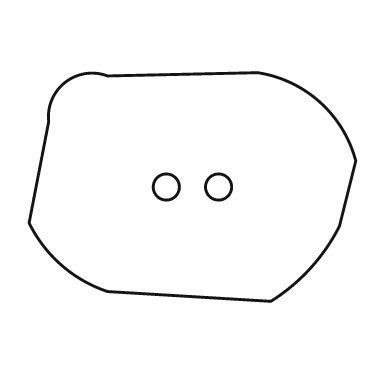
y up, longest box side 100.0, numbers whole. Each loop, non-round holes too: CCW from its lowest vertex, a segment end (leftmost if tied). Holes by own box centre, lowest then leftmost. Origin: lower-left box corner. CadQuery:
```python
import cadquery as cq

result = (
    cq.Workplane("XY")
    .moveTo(74.0, 0.0)
    .threePointArc((86.0, 10.0), (95.0, 23.0))
    .lineTo(100.0, 43.0)
    .threePointArc((89.0, 61.0), (70.0, 70.0))
    .lineTo(24.0, 69.0)
    .threePointArc((11.0, 67.0), (6.0, 55.0))
    .lineTo(0.0, 24.0)
    .threePointArc((10.0, 11.0), (24.0, 3.0))
    .close()
    .moveTo(42.0, 35.0)
    .circle(4.0)
    .moveTo(58.0, 35.0)
    .circle(4.0)
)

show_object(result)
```